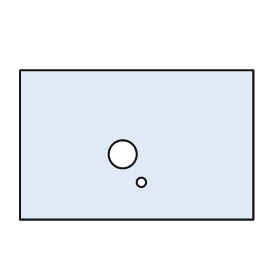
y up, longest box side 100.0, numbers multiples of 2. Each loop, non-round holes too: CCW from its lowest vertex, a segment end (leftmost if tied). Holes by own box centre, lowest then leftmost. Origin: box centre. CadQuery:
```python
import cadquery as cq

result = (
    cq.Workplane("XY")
    .moveTo(-50.0, -32.0)
    .lineTo(50.0, -32.0)
    .lineTo(50.0, 32.0)
    .lineTo(-50.0, 32.0)
    .close()
    .moveTo(2.0, -16.0)
    .circle(2.0)
    .moveTo(-6.0, -4.0)
    .circle(6.0)
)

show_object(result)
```